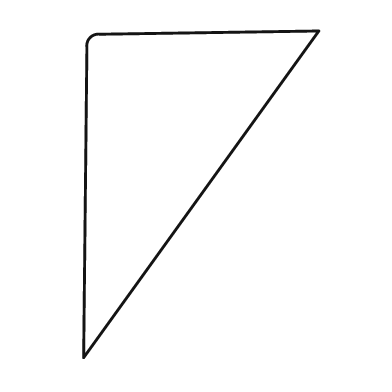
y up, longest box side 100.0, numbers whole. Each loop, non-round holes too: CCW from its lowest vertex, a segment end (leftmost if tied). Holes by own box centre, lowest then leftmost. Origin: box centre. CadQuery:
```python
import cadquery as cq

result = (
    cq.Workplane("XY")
    .moveTo(-36.0, -50.0)
    .lineTo(36.0, 50.0)
    .lineTo(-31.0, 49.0)
    .threePointArc((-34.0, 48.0), (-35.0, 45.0))
    .close()
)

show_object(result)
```